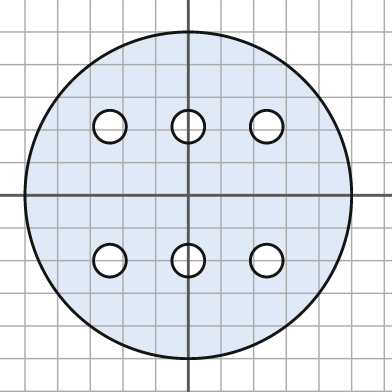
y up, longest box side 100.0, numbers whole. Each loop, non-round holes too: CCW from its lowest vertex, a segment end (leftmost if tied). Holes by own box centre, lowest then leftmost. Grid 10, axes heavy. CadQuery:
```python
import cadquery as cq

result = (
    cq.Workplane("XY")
    .moveTo(0.0, 0.0)
    .circle(50.0)
    .moveTo(-24.0, -20.0)
    .circle(5.0)
    .moveTo(0.0, -20.0)
    .circle(5.0)
    .moveTo(24.0, -20.0)
    .circle(5.0)
    .moveTo(-24.0, 21.0)
    .circle(5.0)
    .moveTo(0.0, 21.0)
    .circle(5.0)
    .moveTo(24.0, 21.0)
    .circle(5.0)
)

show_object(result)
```